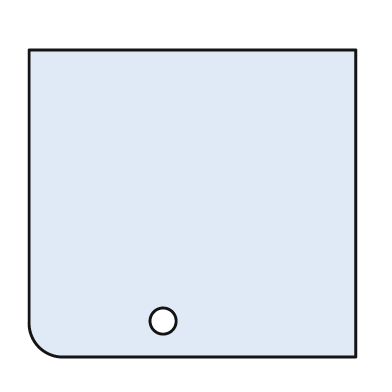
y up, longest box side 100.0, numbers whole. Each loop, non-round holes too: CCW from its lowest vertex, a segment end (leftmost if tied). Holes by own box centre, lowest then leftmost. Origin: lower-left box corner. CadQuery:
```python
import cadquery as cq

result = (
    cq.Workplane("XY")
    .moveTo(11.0, 0.0)
    .lineTo(100.0, 0.0)
    .lineTo(100.0, 94.0)
    .lineTo(0.0, 94.0)
    .lineTo(0.0, 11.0)
    .threePointArc((3.0, 3.0), (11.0, 0.0))
    .close()
    .moveTo(41.0, 11.0)
    .circle(4.0)
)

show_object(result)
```